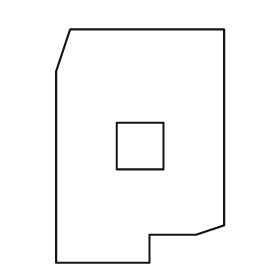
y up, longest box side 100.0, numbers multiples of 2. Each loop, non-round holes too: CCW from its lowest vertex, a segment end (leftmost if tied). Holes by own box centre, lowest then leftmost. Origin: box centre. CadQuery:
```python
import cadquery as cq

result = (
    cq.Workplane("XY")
    .moveTo(-36.0, -50.0)
    .lineTo(4.0, -50.0)
    .lineTo(4.0, -38.0)
    .lineTo(24.0, -38.0)
    .lineTo(36.0, -34.0)
    .lineTo(36.0, 50.0)
    .lineTo(-30.0, 50.0)
    .lineTo(-36.0, 32.0)
    .close()
    .moveTo(-10.0, -10.0)
    .lineTo(10.0, -10.0)
    .lineTo(10.0, 10.0)
    .lineTo(-10.0, 10.0)
    .close()
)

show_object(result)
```